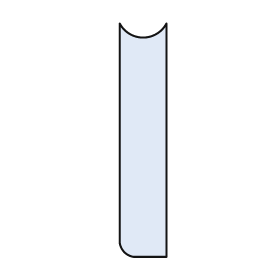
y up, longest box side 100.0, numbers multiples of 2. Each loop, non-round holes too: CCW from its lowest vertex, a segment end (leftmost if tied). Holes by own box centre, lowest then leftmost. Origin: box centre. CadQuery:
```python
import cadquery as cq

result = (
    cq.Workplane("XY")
    .moveTo(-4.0, -50.0)
    .lineTo(10.0, -50.0)
    .lineTo(10.0, 50.0)
    .threePointArc((0.0, 44.0), (-10.0, 50.0))
    .lineTo(-10.0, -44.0)
    .threePointArc((-8.0, -48.0), (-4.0, -50.0))
    .close()
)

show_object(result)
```